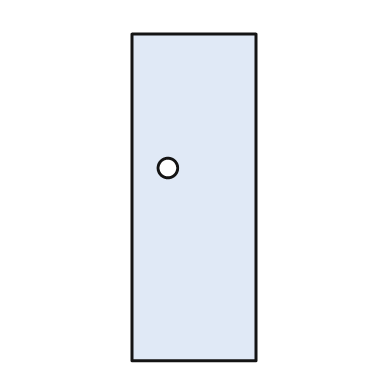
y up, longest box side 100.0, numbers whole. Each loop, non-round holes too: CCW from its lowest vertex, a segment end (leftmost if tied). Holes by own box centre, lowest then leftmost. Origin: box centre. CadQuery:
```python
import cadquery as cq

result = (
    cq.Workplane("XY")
    .moveTo(-19.0, -50.0)
    .lineTo(19.0, -50.0)
    .lineTo(19.0, 50.0)
    .lineTo(-19.0, 50.0)
    .close()
    .moveTo(-8.0, 9.0)
    .circle(3.0)
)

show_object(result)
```